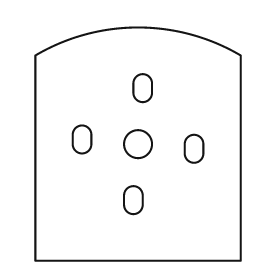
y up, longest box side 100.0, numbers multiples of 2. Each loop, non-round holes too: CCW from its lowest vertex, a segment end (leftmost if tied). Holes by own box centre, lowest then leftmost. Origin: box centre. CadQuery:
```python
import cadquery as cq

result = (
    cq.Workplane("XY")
    .moveTo(-44.0, -50.0)
    .lineTo(44.0, -50.0)
    .lineTo(44.0, 38.0)
    .threePointArc((0.0, 50.0), (-44.0, 38.0))
    .close()
    .moveTo(-6.0, -26.0)
    .threePointArc((-2.0, -30.0), (2.0, -26.0))
    .lineTo(2.0, -22.0)
    .threePointArc((-2.0, -18.0), (-6.0, -22.0))
    .close()
    .moveTo(20.0, -4.0)
    .threePointArc((24.0, -8.0), (28.0, -4.0))
    .lineTo(28.0, 0.0)
    .threePointArc((24.0, 4.0), (20.0, 0.0))
    .close()
    .moveTo(0.0, 0.0)
    .circle(6.0)
    .moveTo(-28.0, 0.0)
    .threePointArc((-24.0, -4.0), (-20.0, 0.0))
    .lineTo(-20.0, 4.0)
    .threePointArc((-24.0, 8.0), (-28.0, 4.0))
    .close()
    .moveTo(-2.0, 22.0)
    .threePointArc((2.0, 18.0), (6.0, 22.0))
    .lineTo(6.0, 26.0)
    .threePointArc((2.0, 30.0), (-2.0, 26.0))
    .close()
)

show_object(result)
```